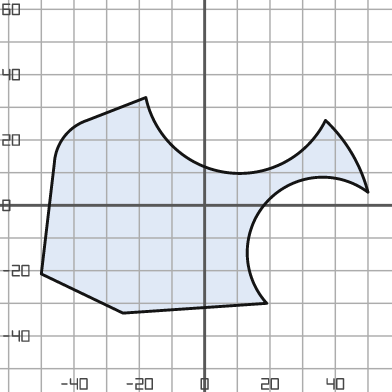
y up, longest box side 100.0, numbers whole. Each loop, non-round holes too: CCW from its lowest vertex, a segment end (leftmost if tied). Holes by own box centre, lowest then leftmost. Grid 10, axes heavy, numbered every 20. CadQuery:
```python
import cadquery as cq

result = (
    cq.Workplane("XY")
    .moveTo(-25.0, -33.0)
    .lineTo(19.0, -30.0)
    .threePointArc((19.0, 1.0), (50.0, 4.0))
    .threePointArc((45.0, 16.0), (37.0, 26.0))
    .threePointArc((7.0, 10.0), (-18.0, 33.0))
    .lineTo(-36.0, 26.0)
    .threePointArc((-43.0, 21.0), (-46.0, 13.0))
    .lineTo(-50.0, -21.0)
    .close()
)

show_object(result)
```